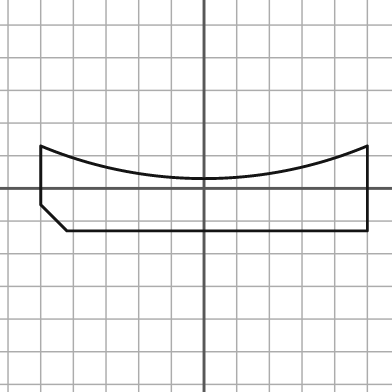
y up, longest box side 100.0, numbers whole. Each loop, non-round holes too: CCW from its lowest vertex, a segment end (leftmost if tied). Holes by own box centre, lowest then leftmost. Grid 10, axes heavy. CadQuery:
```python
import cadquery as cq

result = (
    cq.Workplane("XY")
    .moveTo(-42.0, -13.0)
    .lineTo(50.0, -13.0)
    .lineTo(50.0, 13.0)
    .threePointArc((0.0, 3.0), (-50.0, 13.0))
    .lineTo(-50.0, -5.0)
    .close()
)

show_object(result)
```